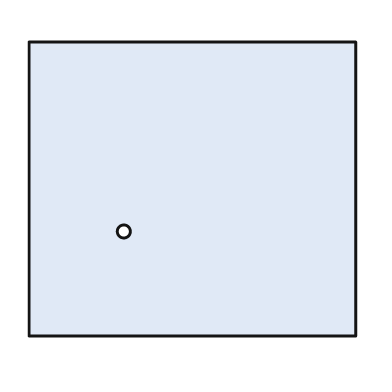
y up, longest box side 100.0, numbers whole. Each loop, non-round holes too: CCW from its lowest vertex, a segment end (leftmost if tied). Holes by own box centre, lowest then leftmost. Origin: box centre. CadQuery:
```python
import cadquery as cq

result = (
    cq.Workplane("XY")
    .moveTo(-50.0, -45.0)
    .lineTo(50.0, -45.0)
    .lineTo(50.0, 45.0)
    .lineTo(-50.0, 45.0)
    .close()
    .moveTo(-21.0, -13.0)
    .circle(2.0)
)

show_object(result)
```